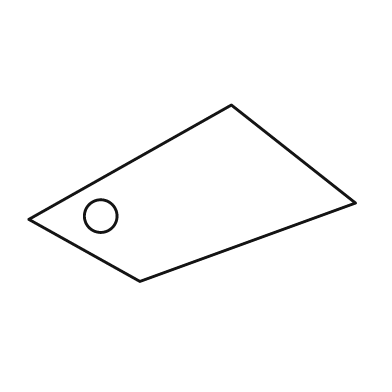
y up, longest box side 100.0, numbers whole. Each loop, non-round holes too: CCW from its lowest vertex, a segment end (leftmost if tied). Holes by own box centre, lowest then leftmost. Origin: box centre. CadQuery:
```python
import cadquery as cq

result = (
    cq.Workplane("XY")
    .moveTo(-16.0, -27.0)
    .lineTo(50.0, -3.0)
    .lineTo(12.0, 27.0)
    .lineTo(-50.0, -8.0)
    .close()
    .moveTo(-28.0, -7.0)
    .circle(5.0)
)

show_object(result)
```